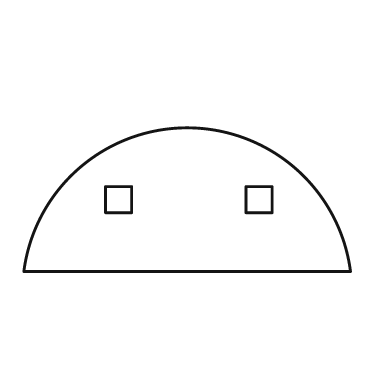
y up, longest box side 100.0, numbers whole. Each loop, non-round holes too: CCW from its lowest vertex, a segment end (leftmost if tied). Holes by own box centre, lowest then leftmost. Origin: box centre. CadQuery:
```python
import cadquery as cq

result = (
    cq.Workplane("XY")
    .moveTo(-50.0, -22.0)
    .lineTo(50.0, -22.0)
    .threePointArc((0.0, 22.0), (-50.0, -22.0))
    .close()
    .moveTo(-25.0, -4.0)
    .lineTo(-17.0, -4.0)
    .lineTo(-17.0, 4.0)
    .lineTo(-25.0, 4.0)
    .close()
    .moveTo(18.0, -4.0)
    .lineTo(26.0, -4.0)
    .lineTo(26.0, 4.0)
    .lineTo(18.0, 4.0)
    .close()
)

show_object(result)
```